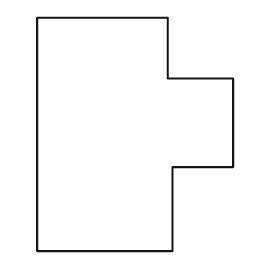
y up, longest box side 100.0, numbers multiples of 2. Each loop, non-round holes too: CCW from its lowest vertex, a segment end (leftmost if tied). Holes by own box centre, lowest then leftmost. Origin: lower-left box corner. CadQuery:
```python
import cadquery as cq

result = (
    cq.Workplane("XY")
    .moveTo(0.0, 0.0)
    .lineTo(58.0, 0.0)
    .lineTo(58.0, 36.0)
    .lineTo(84.0, 36.0)
    .lineTo(84.0, 74.0)
    .lineTo(56.0, 74.0)
    .lineTo(56.0, 100.0)
    .lineTo(0.0, 100.0)
    .close()
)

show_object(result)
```